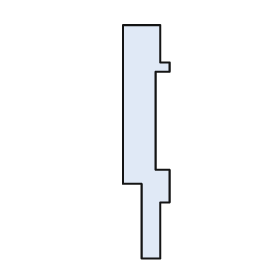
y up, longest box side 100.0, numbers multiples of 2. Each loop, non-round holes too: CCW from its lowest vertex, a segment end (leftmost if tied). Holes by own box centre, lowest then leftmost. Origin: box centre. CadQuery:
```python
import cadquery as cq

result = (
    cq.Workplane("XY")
    .moveTo(-2.0, -50.0)
    .lineTo(6.0, -50.0)
    .lineTo(6.0, -26.0)
    .lineTo(10.0, -26.0)
    .lineTo(10.0, -12.0)
    .lineTo(4.0, -12.0)
    .lineTo(4.0, 30.0)
    .lineTo(10.0, 30.0)
    .lineTo(10.0, 34.0)
    .lineTo(6.0, 34.0)
    .lineTo(6.0, 50.0)
    .lineTo(-10.0, 50.0)
    .lineTo(-10.0, -18.0)
    .lineTo(-2.0, -18.0)
    .close()
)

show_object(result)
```